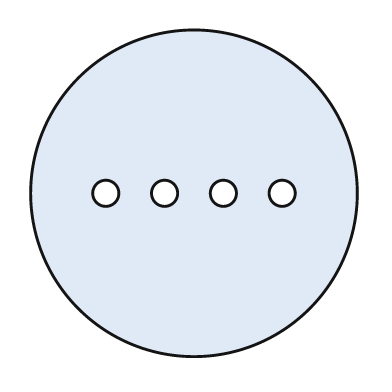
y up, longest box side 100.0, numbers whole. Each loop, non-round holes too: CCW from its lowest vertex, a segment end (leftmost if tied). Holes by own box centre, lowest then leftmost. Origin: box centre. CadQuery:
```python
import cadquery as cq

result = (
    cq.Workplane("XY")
    .moveTo(0.0, 0.0)
    .circle(50.0)
    .moveTo(-27.0, 0.0)
    .circle(4.0)
    .moveTo(-9.0, 0.0)
    .circle(4.0)
    .moveTo(9.0, 0.0)
    .circle(4.0)
    .moveTo(27.0, 0.0)
    .circle(4.0)
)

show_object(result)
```